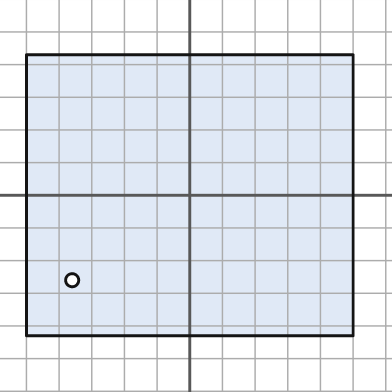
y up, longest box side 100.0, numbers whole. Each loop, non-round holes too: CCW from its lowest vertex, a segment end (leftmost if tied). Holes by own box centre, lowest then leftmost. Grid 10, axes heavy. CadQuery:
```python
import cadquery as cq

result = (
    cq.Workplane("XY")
    .moveTo(-50.0, -43.0)
    .lineTo(50.0, -43.0)
    .lineTo(50.0, 43.0)
    .lineTo(-50.0, 43.0)
    .close()
    .moveTo(-36.0, -26.0)
    .circle(2.0)
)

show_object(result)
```